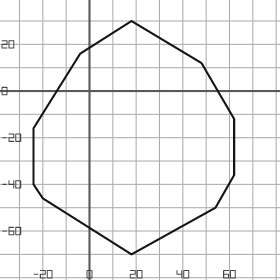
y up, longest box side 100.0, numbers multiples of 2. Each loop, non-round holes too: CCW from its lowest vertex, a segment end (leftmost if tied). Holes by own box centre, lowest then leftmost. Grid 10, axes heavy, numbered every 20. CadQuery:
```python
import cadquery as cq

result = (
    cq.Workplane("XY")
    .moveTo(18.0, -70.0)
    .lineTo(54.0, -50.0)
    .lineTo(62.0, -36.0)
    .lineTo(62.0, -12.0)
    .lineTo(48.0, 12.0)
    .lineTo(18.0, 30.0)
    .lineTo(-4.0, 16.0)
    .lineTo(-24.0, -16.0)
    .lineTo(-24.0, -40.0)
    .lineTo(-20.0, -46.0)
    .close()
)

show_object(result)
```